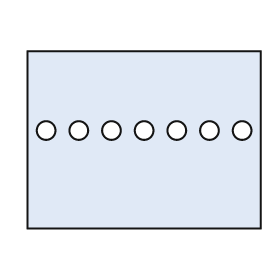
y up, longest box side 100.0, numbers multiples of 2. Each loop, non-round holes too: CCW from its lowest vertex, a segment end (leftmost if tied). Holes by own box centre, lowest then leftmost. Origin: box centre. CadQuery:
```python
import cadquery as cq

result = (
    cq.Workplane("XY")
    .moveTo(-50.0, -38.0)
    .lineTo(50.0, -38.0)
    .lineTo(50.0, 38.0)
    .lineTo(-50.0, 38.0)
    .close()
    .moveTo(-42.0, 4.0)
    .circle(4.0)
    .moveTo(-28.0, 4.0)
    .circle(4.0)
    .moveTo(-14.0, 4.0)
    .circle(4.0)
    .moveTo(0.0, 4.0)
    .circle(4.0)
    .moveTo(14.0, 4.0)
    .circle(4.0)
    .moveTo(28.0, 4.0)
    .circle(4.0)
    .moveTo(42.0, 4.0)
    .circle(4.0)
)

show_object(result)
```